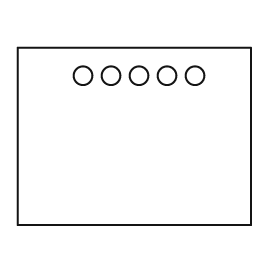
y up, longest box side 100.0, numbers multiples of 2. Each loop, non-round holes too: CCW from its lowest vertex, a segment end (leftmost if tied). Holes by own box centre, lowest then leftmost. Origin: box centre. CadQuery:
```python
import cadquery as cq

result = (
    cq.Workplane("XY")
    .moveTo(-50.0, -38.0)
    .lineTo(50.0, -38.0)
    .lineTo(50.0, 38.0)
    .lineTo(-50.0, 38.0)
    .close()
    .moveTo(-22.0, 26.0)
    .circle(4.0)
    .moveTo(-10.0, 26.0)
    .circle(4.0)
    .moveTo(2.0, 26.0)
    .circle(4.0)
    .moveTo(14.0, 26.0)
    .circle(4.0)
    .moveTo(26.0, 26.0)
    .circle(4.0)
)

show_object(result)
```